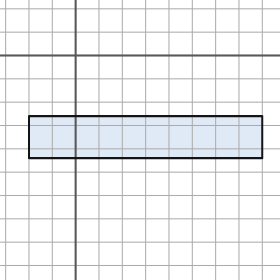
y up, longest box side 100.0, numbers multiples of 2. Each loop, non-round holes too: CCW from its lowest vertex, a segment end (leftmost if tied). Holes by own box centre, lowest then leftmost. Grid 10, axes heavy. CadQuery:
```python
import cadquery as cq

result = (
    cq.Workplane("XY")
    .moveTo(-20.0, -44.0)
    .lineTo(80.0, -44.0)
    .lineTo(80.0, -26.0)
    .lineTo(-20.0, -26.0)
    .close()
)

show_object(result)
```